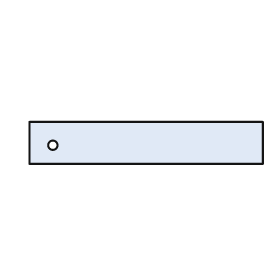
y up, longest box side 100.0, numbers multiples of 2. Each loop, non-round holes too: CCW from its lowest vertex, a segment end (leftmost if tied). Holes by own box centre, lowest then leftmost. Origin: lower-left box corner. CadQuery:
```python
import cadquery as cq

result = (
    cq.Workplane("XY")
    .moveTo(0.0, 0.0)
    .lineTo(100.0, 0.0)
    .lineTo(100.0, 18.0)
    .lineTo(0.0, 18.0)
    .close()
    .moveTo(10.0, 8.0)
    .circle(2.0)
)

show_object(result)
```